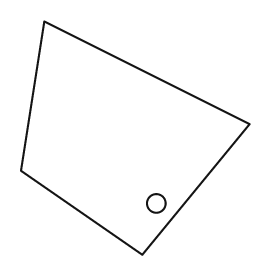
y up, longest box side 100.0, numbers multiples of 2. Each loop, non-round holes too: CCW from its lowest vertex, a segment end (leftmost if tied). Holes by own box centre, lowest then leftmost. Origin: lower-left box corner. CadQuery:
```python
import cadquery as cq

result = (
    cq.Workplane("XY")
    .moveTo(52.0, 0.0)
    .lineTo(98.0, 56.0)
    .lineTo(10.0, 100.0)
    .lineTo(0.0, 36.0)
    .close()
    .moveTo(58.0, 22.0)
    .circle(4.0)
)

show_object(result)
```